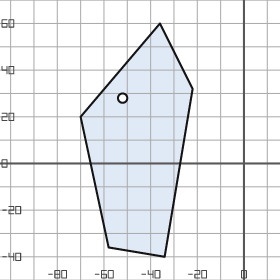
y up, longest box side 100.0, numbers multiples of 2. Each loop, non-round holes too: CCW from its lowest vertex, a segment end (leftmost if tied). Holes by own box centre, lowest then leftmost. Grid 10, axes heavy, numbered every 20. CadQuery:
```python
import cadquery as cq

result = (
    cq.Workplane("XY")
    .moveTo(-34.0, -40.0)
    .lineTo(-22.0, 32.0)
    .lineTo(-36.0, 60.0)
    .lineTo(-70.0, 20.0)
    .lineTo(-58.0, -36.0)
    .close()
    .moveTo(-52.0, 28.0)
    .circle(2.0)
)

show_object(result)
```